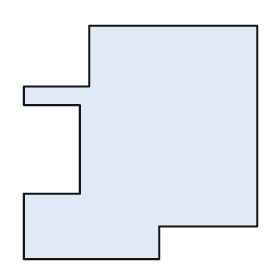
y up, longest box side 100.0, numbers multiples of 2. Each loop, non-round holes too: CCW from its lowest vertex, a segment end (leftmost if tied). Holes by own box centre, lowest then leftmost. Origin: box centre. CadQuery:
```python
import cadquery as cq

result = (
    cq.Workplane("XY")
    .moveTo(-50.0, -50.0)
    .lineTo(8.0, -50.0)
    .lineTo(8.0, -36.0)
    .lineTo(50.0, -36.0)
    .lineTo(50.0, 50.0)
    .lineTo(-22.0, 50.0)
    .lineTo(-22.0, 24.0)
    .lineTo(-50.0, 24.0)
    .lineTo(-50.0, 16.0)
    .lineTo(-26.0, 16.0)
    .lineTo(-26.0, -22.0)
    .lineTo(-50.0, -22.0)
    .close()
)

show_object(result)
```